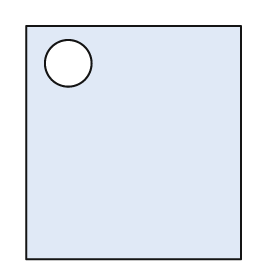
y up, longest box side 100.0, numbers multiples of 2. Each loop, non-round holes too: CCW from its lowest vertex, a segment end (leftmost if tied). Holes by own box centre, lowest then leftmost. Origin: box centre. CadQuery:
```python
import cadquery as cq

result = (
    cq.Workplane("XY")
    .moveTo(-46.0, -50.0)
    .lineTo(46.0, -50.0)
    .lineTo(46.0, 50.0)
    .lineTo(-46.0, 50.0)
    .close()
    .moveTo(-28.0, 34.0)
    .circle(10.0)
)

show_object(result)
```